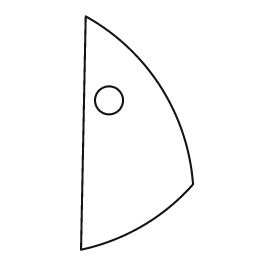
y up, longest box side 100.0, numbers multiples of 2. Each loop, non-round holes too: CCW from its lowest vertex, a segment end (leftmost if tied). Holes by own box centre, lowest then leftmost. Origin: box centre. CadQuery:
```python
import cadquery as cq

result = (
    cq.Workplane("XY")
    .moveTo(-24.0, -50.0)
    .threePointArc((2.0, -40.0), (24.0, -22.0))
    .threePointArc((10.0, 20.0), (-22.0, 50.0))
    .close()
    .moveTo(-12.0, 14.0)
    .circle(6.0)
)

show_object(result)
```